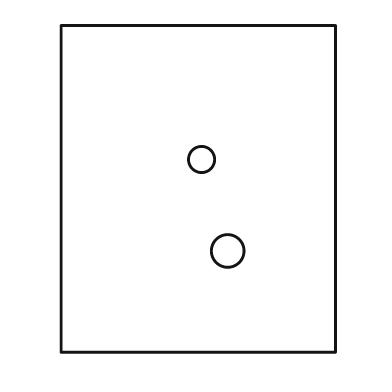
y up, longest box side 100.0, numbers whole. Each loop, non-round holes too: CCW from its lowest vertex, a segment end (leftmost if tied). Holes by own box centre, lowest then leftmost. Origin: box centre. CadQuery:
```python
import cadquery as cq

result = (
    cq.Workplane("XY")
    .moveTo(-42.0, -50.0)
    .lineTo(42.0, -50.0)
    .lineTo(42.0, 50.0)
    .lineTo(-42.0, 50.0)
    .close()
    .moveTo(9.0, -19.0)
    .circle(5.0)
    .moveTo(1.0, 9.0)
    .circle(4.0)
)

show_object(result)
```